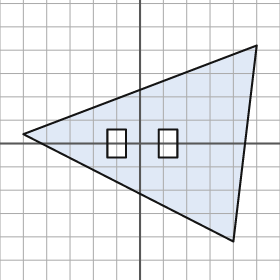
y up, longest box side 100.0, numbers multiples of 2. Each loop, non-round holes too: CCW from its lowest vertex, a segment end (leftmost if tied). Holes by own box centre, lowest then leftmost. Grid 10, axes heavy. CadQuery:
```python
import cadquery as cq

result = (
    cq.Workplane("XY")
    .moveTo(40.0, -42.0)
    .lineTo(50.0, 42.0)
    .lineTo(-50.0, 4.0)
    .close()
    .moveTo(-14.0, -6.0)
    .lineTo(-6.0, -6.0)
    .lineTo(-6.0, 6.0)
    .lineTo(-14.0, 6.0)
    .close()
    .moveTo(8.0, -6.0)
    .lineTo(16.0, -6.0)
    .lineTo(16.0, 6.0)
    .lineTo(8.0, 6.0)
    .close()
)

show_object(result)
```